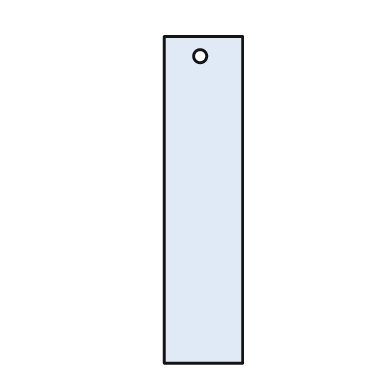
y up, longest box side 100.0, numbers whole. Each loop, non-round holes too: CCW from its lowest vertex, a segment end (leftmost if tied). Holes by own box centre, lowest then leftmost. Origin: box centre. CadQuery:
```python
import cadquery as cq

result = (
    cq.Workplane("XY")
    .moveTo(-12.0, -50.0)
    .lineTo(12.0, -50.0)
    .lineTo(12.0, 50.0)
    .lineTo(-12.0, 50.0)
    .close()
    .moveTo(-1.0, 44.0)
    .circle(2.0)
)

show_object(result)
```